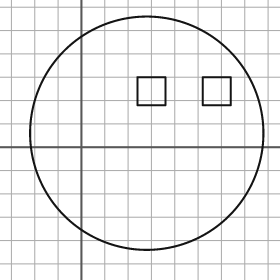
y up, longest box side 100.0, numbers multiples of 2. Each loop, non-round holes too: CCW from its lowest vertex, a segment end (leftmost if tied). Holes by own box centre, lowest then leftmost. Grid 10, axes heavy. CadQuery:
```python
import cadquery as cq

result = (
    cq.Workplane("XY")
    .moveTo(28.0, 6.0)
    .circle(50.0)
    .moveTo(24.0, 18.0)
    .lineTo(36.0, 18.0)
    .lineTo(36.0, 30.0)
    .lineTo(24.0, 30.0)
    .close()
    .moveTo(52.0, 18.0)
    .lineTo(64.0, 18.0)
    .lineTo(64.0, 30.0)
    .lineTo(52.0, 30.0)
    .close()
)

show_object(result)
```